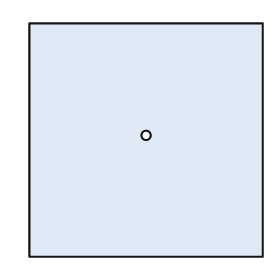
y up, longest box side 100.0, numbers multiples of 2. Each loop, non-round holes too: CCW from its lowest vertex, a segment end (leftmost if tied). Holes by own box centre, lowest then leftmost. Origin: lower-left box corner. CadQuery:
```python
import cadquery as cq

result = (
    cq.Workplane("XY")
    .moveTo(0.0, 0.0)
    .lineTo(100.0, 0.0)
    .lineTo(100.0, 100.0)
    .lineTo(0.0, 100.0)
    .close()
    .moveTo(50.0, 52.0)
    .circle(2.0)
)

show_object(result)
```